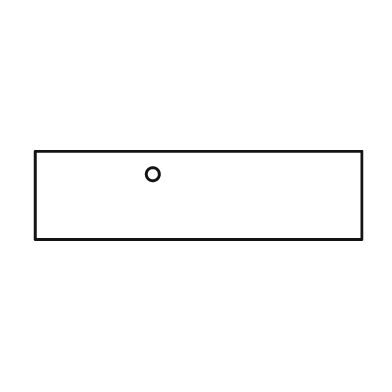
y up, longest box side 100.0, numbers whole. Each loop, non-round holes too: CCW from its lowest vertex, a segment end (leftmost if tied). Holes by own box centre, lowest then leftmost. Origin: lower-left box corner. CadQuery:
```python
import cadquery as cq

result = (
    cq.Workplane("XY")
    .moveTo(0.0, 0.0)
    .lineTo(100.0, 0.0)
    .lineTo(100.0, 27.0)
    .lineTo(0.0, 27.0)
    .close()
    .moveTo(36.0, 20.0)
    .circle(2.0)
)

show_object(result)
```